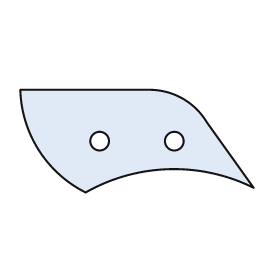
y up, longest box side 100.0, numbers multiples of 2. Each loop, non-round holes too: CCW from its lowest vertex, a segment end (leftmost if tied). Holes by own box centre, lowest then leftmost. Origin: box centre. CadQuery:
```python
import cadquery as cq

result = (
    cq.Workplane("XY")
    .moveTo(-22.0, -22.0)
    .threePointArc((14.0, -12.0), (50.0, -20.0))
    .lineTo(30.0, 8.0)
    .threePointArc((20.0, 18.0), (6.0, 22.0))
    .lineTo(-50.0, 22.0)
    .threePointArc((-42.0, -4.0), (-22.0, -22.0))
    .close()
    .moveTo(-16.0, 0.0)
    .circle(4.0)
    .moveTo(16.0, 0.0)
    .circle(4.0)
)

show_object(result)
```